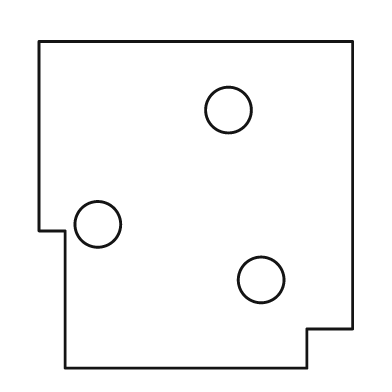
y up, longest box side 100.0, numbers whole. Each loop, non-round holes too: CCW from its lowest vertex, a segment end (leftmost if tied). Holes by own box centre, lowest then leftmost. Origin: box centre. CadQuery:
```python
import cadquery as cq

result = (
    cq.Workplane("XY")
    .moveTo(-40.0, -50.0)
    .lineTo(34.0, -50.0)
    .lineTo(34.0, -38.0)
    .lineTo(48.0, -38.0)
    .lineTo(48.0, 50.0)
    .lineTo(-48.0, 50.0)
    .lineTo(-48.0, -8.0)
    .lineTo(-40.0, -8.0)
    .close()
    .moveTo(20.0, -23.0)
    .circle(7.0)
    .moveTo(-30.0, -6.0)
    .circle(7.0)
    .moveTo(10.0, 29.0)
    .circle(7.0)
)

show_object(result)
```